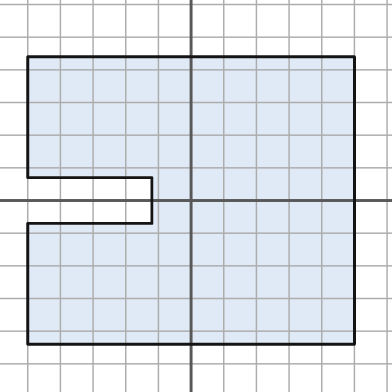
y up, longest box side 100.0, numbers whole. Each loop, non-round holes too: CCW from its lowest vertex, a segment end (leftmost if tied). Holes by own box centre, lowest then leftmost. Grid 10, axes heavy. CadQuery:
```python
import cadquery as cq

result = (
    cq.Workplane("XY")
    .moveTo(-50.0, -44.0)
    .lineTo(50.0, -44.0)
    .lineTo(50.0, 44.0)
    .lineTo(-50.0, 44.0)
    .lineTo(-50.0, 7.0)
    .lineTo(-12.0, 7.0)
    .lineTo(-12.0, -7.0)
    .lineTo(-50.0, -7.0)
    .close()
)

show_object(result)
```